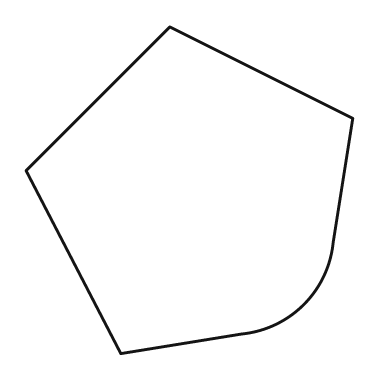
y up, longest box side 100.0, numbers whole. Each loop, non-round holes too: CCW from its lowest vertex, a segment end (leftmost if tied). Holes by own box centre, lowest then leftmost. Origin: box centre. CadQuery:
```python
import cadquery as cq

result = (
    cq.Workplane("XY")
    .moveTo(-21.0, -50.0)
    .lineTo(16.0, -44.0)
    .threePointArc((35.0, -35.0), (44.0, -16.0))
    .lineTo(50.0, 22.0)
    .lineTo(-6.0, 50.0)
    .lineTo(-50.0, 6.0)
    .close()
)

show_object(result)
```